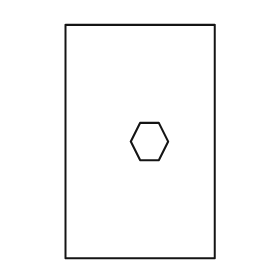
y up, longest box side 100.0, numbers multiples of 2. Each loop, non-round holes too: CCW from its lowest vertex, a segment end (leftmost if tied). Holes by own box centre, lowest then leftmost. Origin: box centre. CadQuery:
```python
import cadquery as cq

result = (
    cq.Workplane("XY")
    .moveTo(-32.0, -50.0)
    .lineTo(32.0, -50.0)
    .lineTo(32.0, 50.0)
    .lineTo(-32.0, 50.0)
    .close()
    .moveTo(0.0, -8.0)
    .lineTo(8.0, -8.0)
    .lineTo(12.0, 0.0)
    .lineTo(8.0, 8.0)
    .lineTo(0.0, 8.0)
    .lineTo(-4.0, 0.0)
    .close()
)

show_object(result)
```